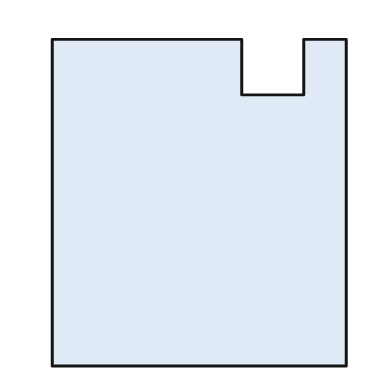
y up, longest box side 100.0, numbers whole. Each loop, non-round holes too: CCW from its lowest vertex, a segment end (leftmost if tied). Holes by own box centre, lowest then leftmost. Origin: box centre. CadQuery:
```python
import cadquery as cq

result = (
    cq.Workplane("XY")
    .moveTo(-45.0, -50.0)
    .lineTo(45.0, -50.0)
    .lineTo(45.0, 50.0)
    .lineTo(32.0, 50.0)
    .lineTo(32.0, 33.0)
    .lineTo(13.0, 33.0)
    .lineTo(13.0, 50.0)
    .lineTo(-45.0, 50.0)
    .close()
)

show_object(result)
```